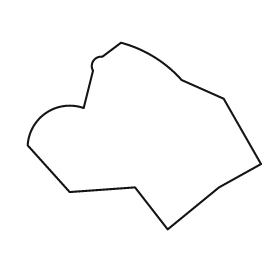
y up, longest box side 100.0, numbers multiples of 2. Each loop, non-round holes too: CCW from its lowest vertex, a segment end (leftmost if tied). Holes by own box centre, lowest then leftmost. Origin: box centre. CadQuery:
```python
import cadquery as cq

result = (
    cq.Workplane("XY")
    .moveTo(10.0, -40.0)
    .lineTo(32.0, -22.0)
    .lineTo(50.0, -12.0)
    .lineTo(34.0, 16.0)
    .lineTo(16.0, 24.0)
    .threePointArc((4.0, 34.0), (-10.0, 40.0))
    .lineTo(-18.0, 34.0)
    .threePointArc((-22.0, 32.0), (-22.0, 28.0))
    .lineTo(-26.0, 12.0)
    .threePointArc((-42.0, 10.0), (-50.0, -4.0))
    .lineTo(-32.0, -24.0)
    .lineTo(-4.0, -22.0)
    .close()
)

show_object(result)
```